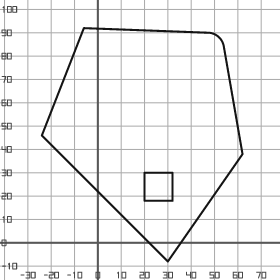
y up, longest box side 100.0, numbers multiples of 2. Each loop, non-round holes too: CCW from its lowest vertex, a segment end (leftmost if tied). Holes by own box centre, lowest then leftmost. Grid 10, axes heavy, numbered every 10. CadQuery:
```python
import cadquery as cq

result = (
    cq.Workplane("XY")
    .moveTo(30.0, -8.0)
    .lineTo(62.0, 38.0)
    .lineTo(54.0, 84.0)
    .threePointArc((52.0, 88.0), (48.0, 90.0))
    .lineTo(-6.0, 92.0)
    .lineTo(-24.0, 46.0)
    .close()
    .moveTo(20.0, 18.0)
    .lineTo(32.0, 18.0)
    .lineTo(32.0, 30.0)
    .lineTo(20.0, 30.0)
    .close()
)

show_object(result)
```